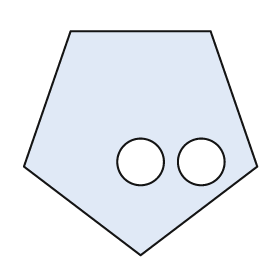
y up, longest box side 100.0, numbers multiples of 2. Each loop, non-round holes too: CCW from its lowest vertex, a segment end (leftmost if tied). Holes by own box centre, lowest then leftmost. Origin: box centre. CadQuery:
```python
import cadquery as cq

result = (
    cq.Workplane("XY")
    .moveTo(0.0, -48.0)
    .lineTo(50.0, -10.0)
    .lineTo(30.0, 48.0)
    .lineTo(-30.0, 48.0)
    .lineTo(-50.0, -10.0)
    .close()
    .moveTo(0.0, -8.0)
    .circle(10.0)
    .moveTo(26.0, -8.0)
    .circle(10.0)
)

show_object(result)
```